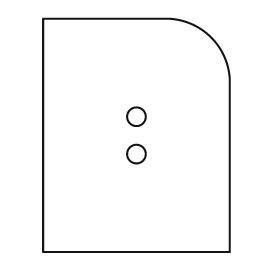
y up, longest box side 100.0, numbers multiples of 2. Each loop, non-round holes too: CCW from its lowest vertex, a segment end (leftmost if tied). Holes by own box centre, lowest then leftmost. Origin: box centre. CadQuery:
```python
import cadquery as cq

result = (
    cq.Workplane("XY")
    .moveTo(-40.0, -50.0)
    .lineTo(40.0, -50.0)
    .lineTo(40.0, 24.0)
    .threePointArc((32.0, 42.0), (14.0, 50.0))
    .lineTo(-40.0, 50.0)
    .close()
    .moveTo(0.0, -8.0)
    .circle(4.0)
    .moveTo(0.0, 8.0)
    .circle(4.0)
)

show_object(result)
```